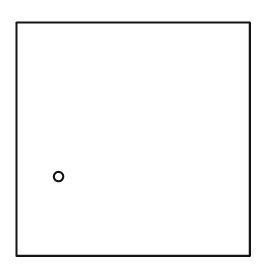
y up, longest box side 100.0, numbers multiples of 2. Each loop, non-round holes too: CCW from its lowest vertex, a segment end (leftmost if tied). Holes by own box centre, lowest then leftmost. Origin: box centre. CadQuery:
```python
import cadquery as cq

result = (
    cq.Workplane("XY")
    .moveTo(-50.0, -50.0)
    .lineTo(50.0, -50.0)
    .lineTo(50.0, 50.0)
    .lineTo(-50.0, 50.0)
    .close()
    .moveTo(-32.0, -16.0)
    .circle(2.0)
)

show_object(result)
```